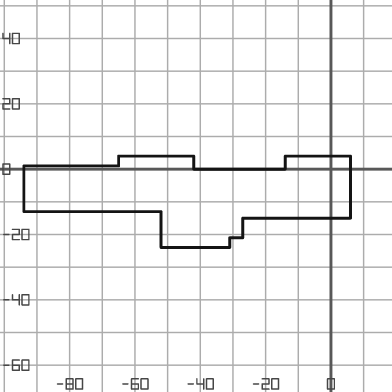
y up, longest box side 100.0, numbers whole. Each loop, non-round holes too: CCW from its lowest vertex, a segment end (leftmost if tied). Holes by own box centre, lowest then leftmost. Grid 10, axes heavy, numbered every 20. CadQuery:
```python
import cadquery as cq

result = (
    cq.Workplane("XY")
    .moveTo(-52.0, -24.0)
    .lineTo(-31.0, -24.0)
    .lineTo(-31.0, -21.0)
    .lineTo(-27.0, -21.0)
    .lineTo(-27.0, -15.0)
    .lineTo(6.0, -15.0)
    .lineTo(6.0, 4.0)
    .lineTo(-14.0, 4.0)
    .lineTo(-14.0, 0.0)
    .lineTo(-42.0, 0.0)
    .lineTo(-42.0, 4.0)
    .lineTo(-65.0, 4.0)
    .lineTo(-65.0, 1.0)
    .lineTo(-94.0, 1.0)
    .lineTo(-94.0, -13.0)
    .lineTo(-52.0, -13.0)
    .close()
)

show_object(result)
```